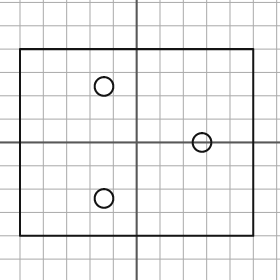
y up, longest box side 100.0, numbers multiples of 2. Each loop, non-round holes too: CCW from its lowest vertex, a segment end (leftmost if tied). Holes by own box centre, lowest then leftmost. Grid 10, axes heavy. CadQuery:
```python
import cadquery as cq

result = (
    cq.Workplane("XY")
    .moveTo(-50.0, -40.0)
    .lineTo(50.0, -40.0)
    .lineTo(50.0, 40.0)
    .lineTo(-50.0, 40.0)
    .close()
    .moveTo(-14.0, -24.0)
    .circle(4.0)
    .moveTo(28.0, 0.0)
    .circle(4.0)
    .moveTo(-14.0, 24.0)
    .circle(4.0)
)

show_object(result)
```